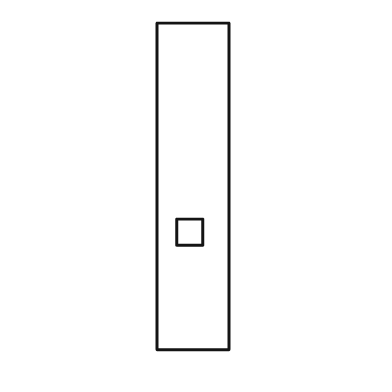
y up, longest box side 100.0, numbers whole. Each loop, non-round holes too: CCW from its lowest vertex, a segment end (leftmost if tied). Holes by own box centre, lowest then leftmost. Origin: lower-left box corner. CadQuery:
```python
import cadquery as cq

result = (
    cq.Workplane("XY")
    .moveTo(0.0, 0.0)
    .lineTo(22.0, 0.0)
    .lineTo(22.0, 100.0)
    .lineTo(0.0, 100.0)
    .close()
    .moveTo(6.0, 32.0)
    .lineTo(14.0, 32.0)
    .lineTo(14.0, 40.0)
    .lineTo(6.0, 40.0)
    .close()
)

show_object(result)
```